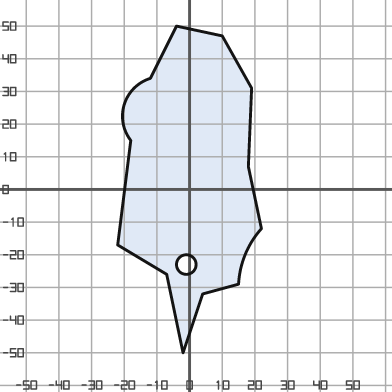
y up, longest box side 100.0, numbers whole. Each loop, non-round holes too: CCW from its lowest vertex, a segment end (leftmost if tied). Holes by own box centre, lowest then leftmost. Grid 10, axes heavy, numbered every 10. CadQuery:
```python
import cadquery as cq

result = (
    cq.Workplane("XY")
    .moveTo(-2.0, -50.0)
    .lineTo(4.0, -32.0)
    .lineTo(15.0, -29.0)
    .threePointArc((17.0, -20.0), (22.0, -12.0))
    .lineTo(18.0, 7.0)
    .lineTo(19.0, 31.0)
    .lineTo(10.0, 47.0)
    .lineTo(-4.0, 50.0)
    .lineTo(-12.0, 34.0)
    .threePointArc((-20.0, 26.0), (-18.0, 15.0))
    .lineTo(-22.0, -17.0)
    .lineTo(-7.0, -26.0)
    .close()
    .moveTo(-1.0, -23.0)
    .circle(3.0)
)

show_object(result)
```